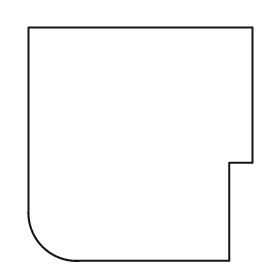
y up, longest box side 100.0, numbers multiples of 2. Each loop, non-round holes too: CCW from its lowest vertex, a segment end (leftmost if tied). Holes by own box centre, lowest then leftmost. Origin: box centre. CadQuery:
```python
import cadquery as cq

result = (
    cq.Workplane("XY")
    .moveTo(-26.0, -50.0)
    .lineTo(38.0, -50.0)
    .lineTo(38.0, -8.0)
    .lineTo(48.0, -8.0)
    .lineTo(48.0, 50.0)
    .lineTo(-48.0, 50.0)
    .lineTo(-48.0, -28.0)
    .threePointArc((-42.0, -44.0), (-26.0, -50.0))
    .close()
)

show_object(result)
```